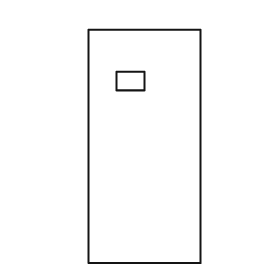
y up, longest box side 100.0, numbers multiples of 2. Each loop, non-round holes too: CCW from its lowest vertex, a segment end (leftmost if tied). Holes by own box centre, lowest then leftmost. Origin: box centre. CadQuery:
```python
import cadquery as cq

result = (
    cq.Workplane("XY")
    .moveTo(-24.0, -50.0)
    .lineTo(24.0, -50.0)
    .lineTo(24.0, 50.0)
    .lineTo(-24.0, 50.0)
    .close()
    .moveTo(-12.0, 24.0)
    .lineTo(0.0, 24.0)
    .lineTo(0.0, 32.0)
    .lineTo(-12.0, 32.0)
    .close()
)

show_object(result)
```